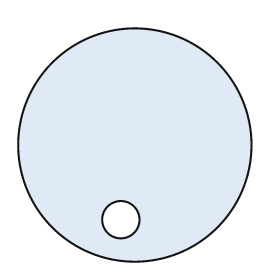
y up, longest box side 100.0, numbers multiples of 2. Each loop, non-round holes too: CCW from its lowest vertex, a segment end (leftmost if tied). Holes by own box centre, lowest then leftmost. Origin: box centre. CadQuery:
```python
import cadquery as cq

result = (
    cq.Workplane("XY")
    .moveTo(0.0, 0.0)
    .circle(50.0)
    .moveTo(-6.0, -32.0)
    .circle(8.0)
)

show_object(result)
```